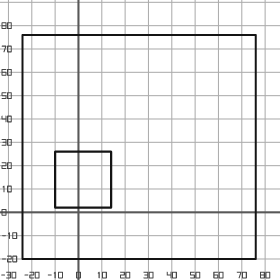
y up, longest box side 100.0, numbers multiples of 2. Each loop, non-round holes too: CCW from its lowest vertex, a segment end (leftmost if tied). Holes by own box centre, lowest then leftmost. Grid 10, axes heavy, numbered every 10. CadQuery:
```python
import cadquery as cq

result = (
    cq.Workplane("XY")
    .moveTo(-24.0, -20.0)
    .lineTo(76.0, -20.0)
    .lineTo(76.0, 76.0)
    .lineTo(-24.0, 76.0)
    .close()
    .moveTo(-10.0, 2.0)
    .lineTo(14.0, 2.0)
    .lineTo(14.0, 26.0)
    .lineTo(-10.0, 26.0)
    .close()
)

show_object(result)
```